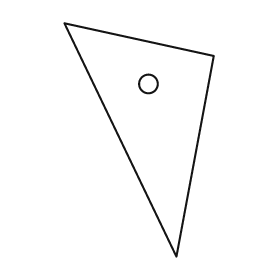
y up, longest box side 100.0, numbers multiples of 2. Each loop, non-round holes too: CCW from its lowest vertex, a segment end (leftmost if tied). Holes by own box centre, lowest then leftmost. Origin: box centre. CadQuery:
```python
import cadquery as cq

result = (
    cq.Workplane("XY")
    .moveTo(16.0, -50.0)
    .lineTo(32.0, 36.0)
    .lineTo(-32.0, 50.0)
    .close()
    .moveTo(4.0, 24.0)
    .circle(4.0)
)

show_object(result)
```